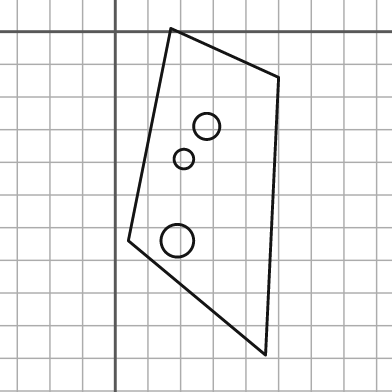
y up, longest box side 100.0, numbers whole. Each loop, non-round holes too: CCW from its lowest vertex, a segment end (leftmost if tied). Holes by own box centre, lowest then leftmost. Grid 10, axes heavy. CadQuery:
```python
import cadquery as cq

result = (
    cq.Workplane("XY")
    .moveTo(46.0, -99.0)
    .lineTo(50.0, -14.0)
    .lineTo(17.0, 1.0)
    .lineTo(4.0, -64.0)
    .close()
    .moveTo(19.0, -64.0)
    .circle(5.0)
    .moveTo(21.0, -39.0)
    .circle(3.0)
    .moveTo(28.0, -29.0)
    .circle(4.0)
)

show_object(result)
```